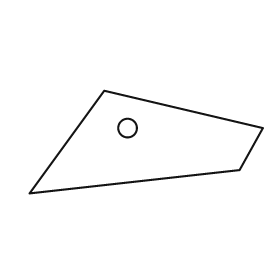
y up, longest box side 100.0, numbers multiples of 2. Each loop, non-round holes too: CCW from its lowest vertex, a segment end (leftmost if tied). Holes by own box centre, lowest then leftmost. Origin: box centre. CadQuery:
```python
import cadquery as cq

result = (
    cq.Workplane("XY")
    .moveTo(-50.0, -22.0)
    .lineTo(40.0, -12.0)
    .lineTo(50.0, 6.0)
    .lineTo(-18.0, 22.0)
    .close()
    .moveTo(-8.0, 6.0)
    .circle(4.0)
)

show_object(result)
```